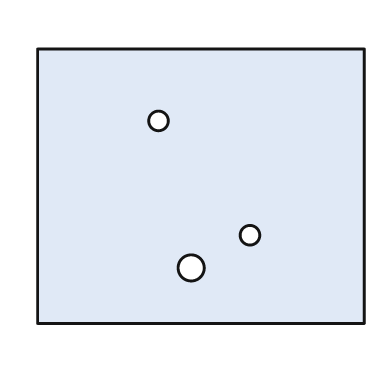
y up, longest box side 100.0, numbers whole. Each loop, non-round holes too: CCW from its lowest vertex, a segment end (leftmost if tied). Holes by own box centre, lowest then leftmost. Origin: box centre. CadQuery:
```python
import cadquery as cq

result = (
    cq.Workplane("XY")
    .moveTo(-50.0, -42.0)
    .lineTo(50.0, -42.0)
    .lineTo(50.0, 42.0)
    .lineTo(-50.0, 42.0)
    .close()
    .moveTo(-3.0, -25.0)
    .circle(4.0)
    .moveTo(15.0, -15.0)
    .circle(3.0)
    .moveTo(-13.0, 20.0)
    .circle(3.0)
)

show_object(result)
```